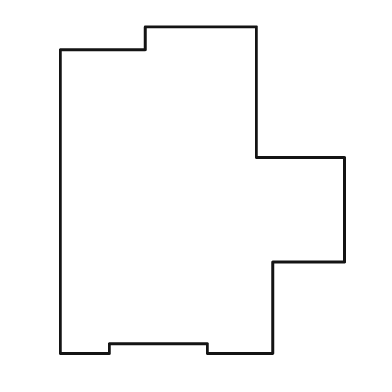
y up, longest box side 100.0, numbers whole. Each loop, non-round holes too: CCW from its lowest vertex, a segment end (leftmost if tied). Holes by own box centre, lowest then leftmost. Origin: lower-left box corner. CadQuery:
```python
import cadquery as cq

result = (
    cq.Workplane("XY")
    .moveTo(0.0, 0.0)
    .lineTo(15.0, 0.0)
    .lineTo(15.0, 3.0)
    .lineTo(45.0, 3.0)
    .lineTo(45.0, 0.0)
    .lineTo(65.0, 0.0)
    .lineTo(65.0, 28.0)
    .lineTo(87.0, 28.0)
    .lineTo(87.0, 60.0)
    .lineTo(60.0, 60.0)
    .lineTo(60.0, 100.0)
    .lineTo(26.0, 100.0)
    .lineTo(26.0, 93.0)
    .lineTo(0.0, 93.0)
    .close()
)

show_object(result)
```